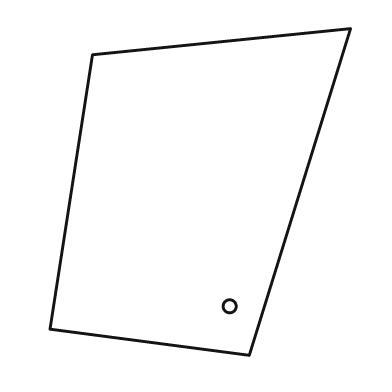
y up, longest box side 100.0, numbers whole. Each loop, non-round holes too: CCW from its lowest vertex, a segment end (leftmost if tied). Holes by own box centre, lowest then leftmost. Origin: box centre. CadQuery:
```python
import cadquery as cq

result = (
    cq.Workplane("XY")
    .moveTo(15.0, -50.0)
    .lineTo(46.0, 50.0)
    .lineTo(-33.0, 42.0)
    .lineTo(-46.0, -42.0)
    .close()
    .moveTo(9.0, -35.0)
    .circle(2.0)
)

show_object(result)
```